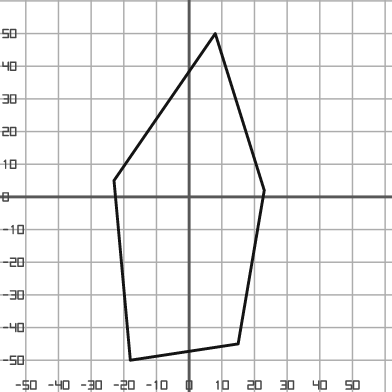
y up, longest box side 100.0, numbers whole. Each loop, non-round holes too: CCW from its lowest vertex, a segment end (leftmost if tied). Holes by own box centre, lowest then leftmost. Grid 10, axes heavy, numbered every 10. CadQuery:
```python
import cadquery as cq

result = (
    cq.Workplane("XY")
    .moveTo(-18.0, -50.0)
    .lineTo(15.0, -45.0)
    .lineTo(23.0, 2.0)
    .lineTo(8.0, 50.0)
    .lineTo(-23.0, 5.0)
    .close()
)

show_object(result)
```